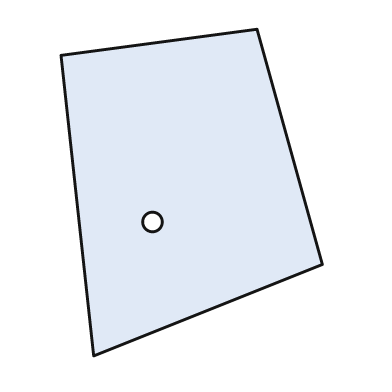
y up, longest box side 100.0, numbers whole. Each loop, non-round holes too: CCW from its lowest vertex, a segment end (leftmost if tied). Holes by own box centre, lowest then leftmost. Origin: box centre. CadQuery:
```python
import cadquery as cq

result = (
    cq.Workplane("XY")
    .moveTo(-30.0, -50.0)
    .lineTo(40.0, -22.0)
    .lineTo(20.0, 50.0)
    .lineTo(-40.0, 42.0)
    .close()
    .moveTo(-12.0, -9.0)
    .circle(3.0)
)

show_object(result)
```